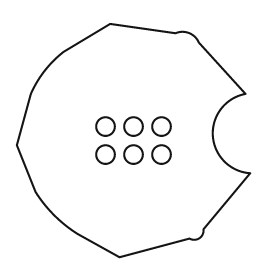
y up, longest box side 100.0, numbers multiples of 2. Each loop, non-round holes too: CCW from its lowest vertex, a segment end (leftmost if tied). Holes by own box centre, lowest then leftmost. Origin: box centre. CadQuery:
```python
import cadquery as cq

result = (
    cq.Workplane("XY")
    .moveTo(-6.0, -50.0)
    .lineTo(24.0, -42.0)
    .threePointArc((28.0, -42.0), (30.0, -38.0))
    .lineTo(50.0, -14.0)
    .threePointArc((34.0, 2.0), (48.0, 20.0))
    .lineTo(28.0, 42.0)
    .threePointArc((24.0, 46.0), (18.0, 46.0))
    .lineTo(-10.0, 50.0)
    .lineTo(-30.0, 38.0)
    .threePointArc((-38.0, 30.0), (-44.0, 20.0))
    .lineTo(-50.0, -2.0)
    .lineTo(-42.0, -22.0)
    .threePointArc((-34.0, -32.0), (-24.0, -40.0))
    .close()
    .moveTo(-12.0, -6.0)
    .circle(4.0)
    .moveTo(0.0, -6.0)
    .circle(4.0)
    .moveTo(12.0, -6.0)
    .circle(4.0)
    .moveTo(-12.0, 6.0)
    .circle(4.0)
    .moveTo(0.0, 6.0)
    .circle(4.0)
    .moveTo(12.0, 6.0)
    .circle(4.0)
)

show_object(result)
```